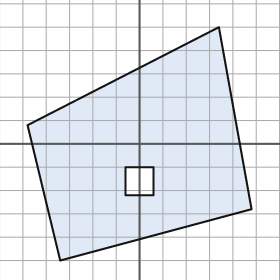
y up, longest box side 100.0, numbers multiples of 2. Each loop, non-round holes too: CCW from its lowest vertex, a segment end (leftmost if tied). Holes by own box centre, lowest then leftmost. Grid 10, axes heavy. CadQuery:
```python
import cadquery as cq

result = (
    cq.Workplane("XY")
    .moveTo(-34.0, -50.0)
    .lineTo(48.0, -28.0)
    .lineTo(34.0, 50.0)
    .lineTo(-48.0, 8.0)
    .close()
    .moveTo(-6.0, -22.0)
    .lineTo(6.0, -22.0)
    .lineTo(6.0, -10.0)
    .lineTo(-6.0, -10.0)
    .close()
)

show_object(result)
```